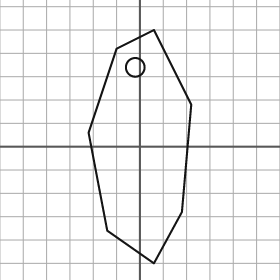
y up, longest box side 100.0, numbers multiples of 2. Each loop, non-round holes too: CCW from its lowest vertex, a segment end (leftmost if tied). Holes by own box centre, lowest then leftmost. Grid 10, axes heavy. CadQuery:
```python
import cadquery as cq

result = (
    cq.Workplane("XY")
    .moveTo(6.0, -50.0)
    .lineTo(18.0, -28.0)
    .lineTo(22.0, 18.0)
    .lineTo(6.0, 50.0)
    .lineTo(-10.0, 42.0)
    .lineTo(-22.0, 6.0)
    .lineTo(-14.0, -36.0)
    .close()
    .moveTo(-2.0, 34.0)
    .circle(4.0)
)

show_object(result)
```